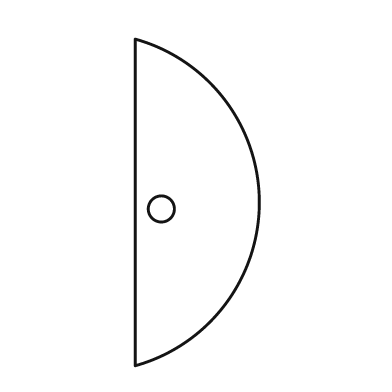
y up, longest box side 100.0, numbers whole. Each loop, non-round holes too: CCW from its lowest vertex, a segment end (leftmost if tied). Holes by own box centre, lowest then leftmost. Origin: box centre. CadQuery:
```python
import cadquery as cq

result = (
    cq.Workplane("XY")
    .moveTo(-19.0, -50.0)
    .threePointArc((19.0, 0.0), (-19.0, 50.0))
    .close()
    .moveTo(-11.0, -2.0)
    .circle(4.0)
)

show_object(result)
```